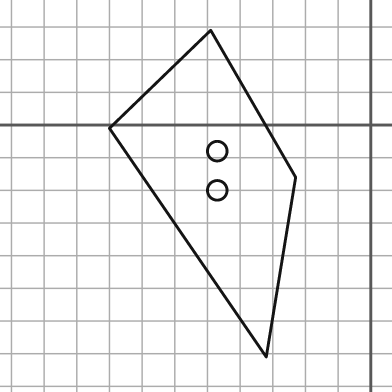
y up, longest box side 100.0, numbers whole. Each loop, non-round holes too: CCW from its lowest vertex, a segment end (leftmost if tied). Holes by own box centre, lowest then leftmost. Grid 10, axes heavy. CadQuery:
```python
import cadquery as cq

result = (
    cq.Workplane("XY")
    .moveTo(-32.0, -71.0)
    .lineTo(-23.0, -16.0)
    .lineTo(-49.0, 29.0)
    .lineTo(-80.0, -1.0)
    .close()
    .moveTo(-47.0, -20.0)
    .circle(3.0)
    .moveTo(-47.0, -8.0)
    .circle(3.0)
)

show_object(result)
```